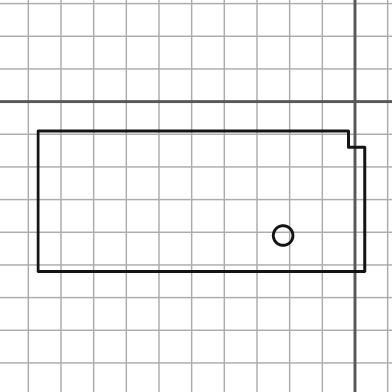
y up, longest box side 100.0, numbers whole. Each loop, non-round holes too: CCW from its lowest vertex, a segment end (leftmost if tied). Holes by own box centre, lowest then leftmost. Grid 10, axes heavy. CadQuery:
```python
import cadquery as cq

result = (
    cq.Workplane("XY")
    .moveTo(-97.0, -52.0)
    .lineTo(3.0, -52.0)
    .lineTo(3.0, -14.0)
    .lineTo(-2.0, -14.0)
    .lineTo(-2.0, -9.0)
    .lineTo(-97.0, -9.0)
    .close()
    .moveTo(-22.0, -41.0)
    .circle(3.0)
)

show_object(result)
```